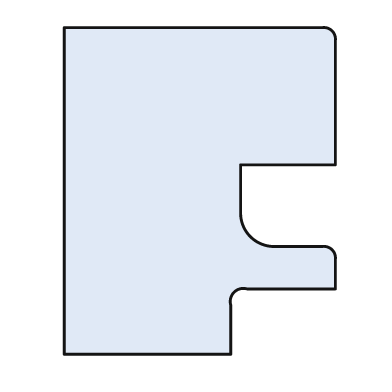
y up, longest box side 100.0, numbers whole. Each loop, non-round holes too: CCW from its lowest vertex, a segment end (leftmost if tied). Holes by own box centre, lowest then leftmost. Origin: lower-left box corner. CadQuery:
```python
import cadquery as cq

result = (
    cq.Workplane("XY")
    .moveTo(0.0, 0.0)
    .lineTo(51.0, 0.0)
    .lineTo(51.0, 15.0)
    .threePointArc((52.0, 19.0), (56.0, 20.0))
    .lineTo(83.0, 20.0)
    .lineTo(83.0, 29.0)
    .threePointArc((82.0, 32.0), (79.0, 33.0))
    .lineTo(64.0, 33.0)
    .threePointArc((57.0, 36.0), (54.0, 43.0))
    .lineTo(54.0, 58.0)
    .lineTo(83.0, 58.0)
    .lineTo(83.0, 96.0)
    .threePointArc((82.0, 99.0), (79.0, 100.0))
    .lineTo(0.0, 100.0)
    .close()
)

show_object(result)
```